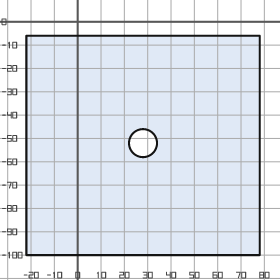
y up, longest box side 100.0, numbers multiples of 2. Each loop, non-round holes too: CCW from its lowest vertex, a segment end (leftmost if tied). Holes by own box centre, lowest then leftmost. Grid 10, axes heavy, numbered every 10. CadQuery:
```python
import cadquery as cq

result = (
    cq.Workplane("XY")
    .moveTo(-22.0, -100.0)
    .lineTo(78.0, -100.0)
    .lineTo(78.0, -6.0)
    .lineTo(-22.0, -6.0)
    .close()
    .moveTo(28.0, -52.0)
    .circle(6.0)
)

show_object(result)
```